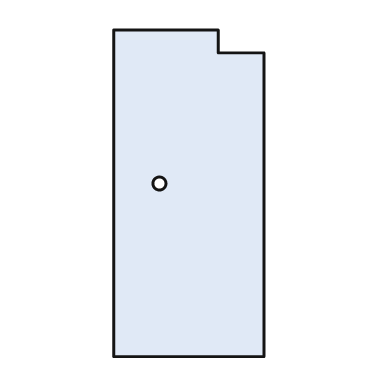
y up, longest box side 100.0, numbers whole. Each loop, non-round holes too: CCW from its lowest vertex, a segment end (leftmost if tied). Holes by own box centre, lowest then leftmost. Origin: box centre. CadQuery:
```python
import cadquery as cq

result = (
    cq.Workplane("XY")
    .moveTo(-23.0, -50.0)
    .lineTo(23.0, -50.0)
    .lineTo(23.0, 43.0)
    .lineTo(9.0, 43.0)
    .lineTo(9.0, 50.0)
    .lineTo(-23.0, 50.0)
    .close()
    .moveTo(-9.0, 3.0)
    .circle(2.0)
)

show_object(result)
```